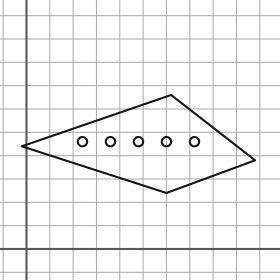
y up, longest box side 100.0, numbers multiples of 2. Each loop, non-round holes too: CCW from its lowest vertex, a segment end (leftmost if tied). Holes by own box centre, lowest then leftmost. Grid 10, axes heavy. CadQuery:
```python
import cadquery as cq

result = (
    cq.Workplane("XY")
    .moveTo(60.0, 24.0)
    .lineTo(98.0, 38.0)
    .lineTo(62.0, 66.0)
    .lineTo(-2.0, 44.0)
    .close()
    .moveTo(24.0, 46.0)
    .circle(2.0)
    .moveTo(36.0, 46.0)
    .circle(2.0)
    .moveTo(48.0, 46.0)
    .circle(2.0)
    .moveTo(60.0, 46.0)
    .circle(2.0)
    .moveTo(72.0, 46.0)
    .circle(2.0)
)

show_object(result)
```